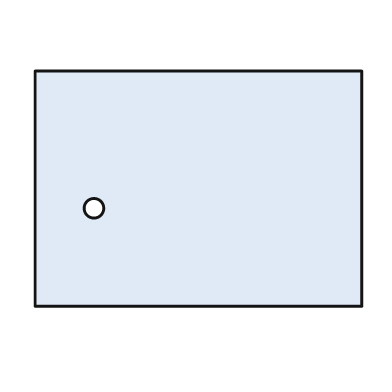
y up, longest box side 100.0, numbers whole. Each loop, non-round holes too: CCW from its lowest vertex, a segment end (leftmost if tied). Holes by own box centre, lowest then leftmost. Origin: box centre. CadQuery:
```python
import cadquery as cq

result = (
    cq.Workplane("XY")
    .moveTo(-50.0, -36.0)
    .lineTo(50.0, -36.0)
    .lineTo(50.0, 36.0)
    .lineTo(-50.0, 36.0)
    .close()
    .moveTo(-32.0, -6.0)
    .circle(3.0)
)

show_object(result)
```